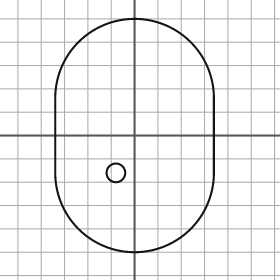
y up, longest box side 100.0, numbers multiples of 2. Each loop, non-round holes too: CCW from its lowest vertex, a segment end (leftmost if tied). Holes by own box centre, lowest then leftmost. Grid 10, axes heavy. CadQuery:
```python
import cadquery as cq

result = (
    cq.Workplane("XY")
    .moveTo(-34.0, -16.0)
    .threePointArc((0.0, -50.0), (34.0, -16.0))
    .lineTo(34.0, 16.0)
    .threePointArc((0.0, 50.0), (-34.0, 16.0))
    .close()
    .moveTo(-8.0, -16.0)
    .circle(4.0)
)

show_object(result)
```